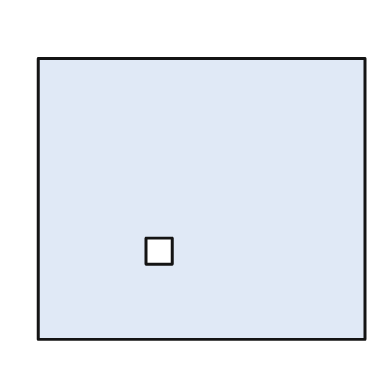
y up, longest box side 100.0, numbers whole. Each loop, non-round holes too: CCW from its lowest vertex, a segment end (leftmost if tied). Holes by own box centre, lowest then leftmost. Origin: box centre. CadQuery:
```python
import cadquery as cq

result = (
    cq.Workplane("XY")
    .moveTo(-50.0, -43.0)
    .lineTo(50.0, -43.0)
    .lineTo(50.0, 43.0)
    .lineTo(-50.0, 43.0)
    .close()
    .moveTo(-17.0, -20.0)
    .lineTo(-9.0, -20.0)
    .lineTo(-9.0, -12.0)
    .lineTo(-17.0, -12.0)
    .close()
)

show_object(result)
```